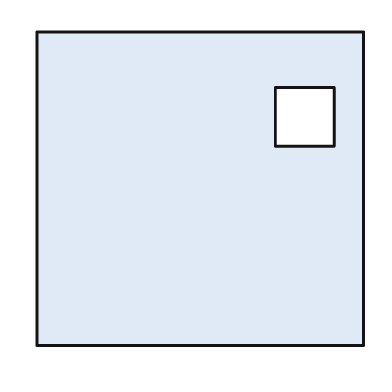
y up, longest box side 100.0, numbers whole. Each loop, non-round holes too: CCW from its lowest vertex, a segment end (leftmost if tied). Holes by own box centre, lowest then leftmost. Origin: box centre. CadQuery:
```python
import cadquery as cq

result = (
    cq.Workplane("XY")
    .moveTo(-50.0, -48.0)
    .lineTo(50.0, -48.0)
    .lineTo(50.0, 48.0)
    .lineTo(-50.0, 48.0)
    .close()
    .moveTo(23.0, 13.0)
    .lineTo(41.0, 13.0)
    .lineTo(41.0, 31.0)
    .lineTo(23.0, 31.0)
    .close()
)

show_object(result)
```